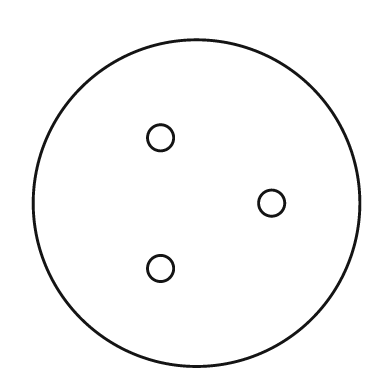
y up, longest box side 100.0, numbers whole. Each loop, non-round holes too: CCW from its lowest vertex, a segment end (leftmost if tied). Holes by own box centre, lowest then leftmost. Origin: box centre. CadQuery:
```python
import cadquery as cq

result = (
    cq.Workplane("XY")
    .moveTo(0.0, 0.0)
    .circle(50.0)
    .moveTo(-11.0, -20.0)
    .circle(4.0)
    .moveTo(23.0, 0.0)
    .circle(4.0)
    .moveTo(-11.0, 20.0)
    .circle(4.0)
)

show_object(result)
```